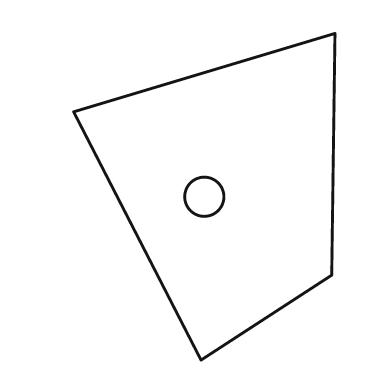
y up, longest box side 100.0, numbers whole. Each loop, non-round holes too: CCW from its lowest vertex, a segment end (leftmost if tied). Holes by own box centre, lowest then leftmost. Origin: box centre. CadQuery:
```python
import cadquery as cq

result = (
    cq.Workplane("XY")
    .moveTo(-1.0, -50.0)
    .lineTo(39.0, -24.0)
    .lineTo(40.0, 50.0)
    .lineTo(-40.0, 26.0)
    .close()
    .moveTo(0.0, 0.0)
    .circle(6.0)
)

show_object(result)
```